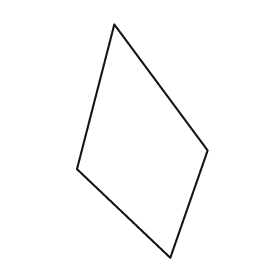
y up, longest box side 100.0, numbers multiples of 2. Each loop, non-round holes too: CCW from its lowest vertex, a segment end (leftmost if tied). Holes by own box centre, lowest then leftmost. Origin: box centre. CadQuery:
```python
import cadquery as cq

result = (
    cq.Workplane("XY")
    .moveTo(12.0, -50.0)
    .lineTo(28.0, -4.0)
    .lineTo(-12.0, 50.0)
    .lineTo(-28.0, -12.0)
    .close()
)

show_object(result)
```